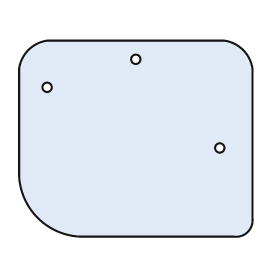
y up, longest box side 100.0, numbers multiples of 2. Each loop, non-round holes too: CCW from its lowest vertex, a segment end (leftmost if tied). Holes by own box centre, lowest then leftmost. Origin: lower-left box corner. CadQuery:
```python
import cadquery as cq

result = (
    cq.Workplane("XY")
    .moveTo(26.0, 0.0)
    .lineTo(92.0, 0.0)
    .threePointArc((98.0, 2.0), (100.0, 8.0))
    .lineTo(100.0, 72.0)
    .threePointArc((96.0, 80.0), (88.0, 84.0))
    .lineTo(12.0, 84.0)
    .threePointArc((4.0, 80.0), (0.0, 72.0))
    .lineTo(0.0, 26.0)
    .threePointArc((8.0, 8.0), (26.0, 0.0))
    .close()
    .moveTo(86.0, 38.0)
    .circle(2.0)
    .moveTo(12.0, 64.0)
    .circle(2.0)
    .moveTo(50.0, 76.0)
    .circle(2.0)
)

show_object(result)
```